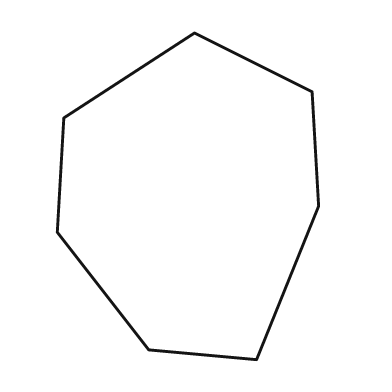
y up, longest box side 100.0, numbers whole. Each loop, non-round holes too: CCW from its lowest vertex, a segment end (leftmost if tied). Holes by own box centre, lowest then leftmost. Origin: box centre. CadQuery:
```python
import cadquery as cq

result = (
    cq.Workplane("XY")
    .moveTo(21.0, -50.0)
    .lineTo(40.0, -3.0)
    .lineTo(38.0, 32.0)
    .lineTo(2.0, 50.0)
    .lineTo(-38.0, 24.0)
    .lineTo(-40.0, -11.0)
    .lineTo(-12.0, -47.0)
    .close()
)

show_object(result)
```